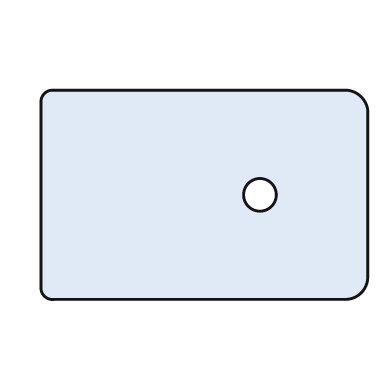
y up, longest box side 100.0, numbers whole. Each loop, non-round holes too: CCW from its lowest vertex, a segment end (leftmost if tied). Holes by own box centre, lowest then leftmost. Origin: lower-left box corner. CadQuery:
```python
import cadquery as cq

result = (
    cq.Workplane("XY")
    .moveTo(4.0, 0.0)
    .lineTo(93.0, 0.0)
    .threePointArc((98.0, 2.0), (100.0, 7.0))
    .lineTo(100.0, 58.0)
    .threePointArc((98.0, 62.0), (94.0, 64.0))
    .lineTo(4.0, 64.0)
    .threePointArc((1.0, 63.0), (0.0, 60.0))
    .lineTo(0.0, 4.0)
    .threePointArc((1.0, 1.0), (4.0, 0.0))
    .close()
    .moveTo(67.0, 32.0)
    .circle(5.0)
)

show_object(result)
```